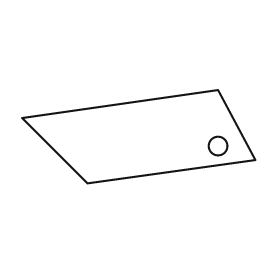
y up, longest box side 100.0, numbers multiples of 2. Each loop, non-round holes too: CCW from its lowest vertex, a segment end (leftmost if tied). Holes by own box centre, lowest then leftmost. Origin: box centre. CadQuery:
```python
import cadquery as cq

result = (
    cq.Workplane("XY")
    .moveTo(-22.0, -20.0)
    .lineTo(50.0, -10.0)
    .lineTo(34.0, 20.0)
    .lineTo(-50.0, 8.0)
    .close()
    .moveTo(34.0, -4.0)
    .circle(4.0)
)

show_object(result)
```